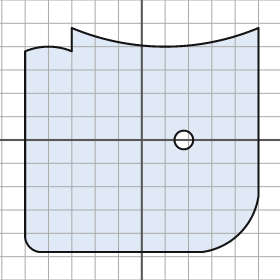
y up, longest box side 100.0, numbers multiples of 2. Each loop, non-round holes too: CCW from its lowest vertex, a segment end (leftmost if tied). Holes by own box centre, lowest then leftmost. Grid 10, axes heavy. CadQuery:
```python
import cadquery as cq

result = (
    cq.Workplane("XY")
    .moveTo(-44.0, -48.0)
    .lineTo(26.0, -48.0)
    .threePointArc((42.0, -40.0), (50.0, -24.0))
    .lineTo(50.0, 48.0)
    .threePointArc((10.0, 40.0), (-30.0, 48.0))
    .lineTo(-30.0, 38.0)
    .threePointArc((-40.0, 40.0), (-50.0, 38.0))
    .lineTo(-50.0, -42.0)
    .threePointArc((-48.0, -46.0), (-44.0, -48.0))
    .close()
    .moveTo(18.0, 0.0)
    .circle(4.0)
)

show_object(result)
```